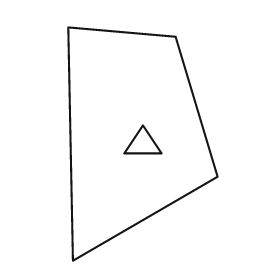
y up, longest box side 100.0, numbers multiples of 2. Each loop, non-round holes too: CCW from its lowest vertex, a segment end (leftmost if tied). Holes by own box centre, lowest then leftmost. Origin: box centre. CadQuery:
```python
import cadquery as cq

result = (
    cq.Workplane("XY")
    .moveTo(-30.0, -50.0)
    .lineTo(32.0, -14.0)
    .lineTo(14.0, 46.0)
    .lineTo(-32.0, 50.0)
    .close()
    .moveTo(-8.0, -4.0)
    .lineTo(8.0, -4.0)
    .lineTo(0.0, 8.0)
    .close()
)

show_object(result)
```